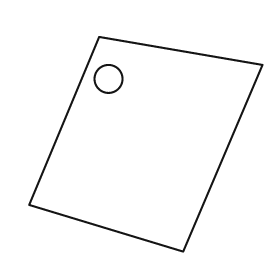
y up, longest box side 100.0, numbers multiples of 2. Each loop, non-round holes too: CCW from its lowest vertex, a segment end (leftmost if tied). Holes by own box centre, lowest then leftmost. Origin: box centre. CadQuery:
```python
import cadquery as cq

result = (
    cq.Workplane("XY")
    .moveTo(16.0, -46.0)
    .lineTo(50.0, 34.0)
    .lineTo(-20.0, 46.0)
    .lineTo(-50.0, -26.0)
    .close()
    .moveTo(-16.0, 28.0)
    .circle(6.0)
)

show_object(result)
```